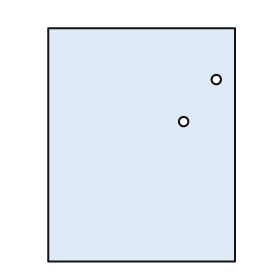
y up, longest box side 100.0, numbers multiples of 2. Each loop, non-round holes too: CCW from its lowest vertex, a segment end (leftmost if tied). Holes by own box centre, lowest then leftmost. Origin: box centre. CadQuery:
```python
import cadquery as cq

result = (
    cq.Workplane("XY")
    .moveTo(-40.0, -50.0)
    .lineTo(40.0, -50.0)
    .lineTo(40.0, 50.0)
    .lineTo(-40.0, 50.0)
    .close()
    .moveTo(18.0, 10.0)
    .circle(2.0)
    .moveTo(32.0, 28.0)
    .circle(2.0)
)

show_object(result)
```